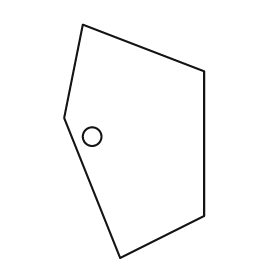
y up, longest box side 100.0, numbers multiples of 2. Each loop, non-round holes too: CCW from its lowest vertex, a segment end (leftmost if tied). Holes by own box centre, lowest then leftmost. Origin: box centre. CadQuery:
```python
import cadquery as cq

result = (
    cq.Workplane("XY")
    .moveTo(-6.0, -50.0)
    .lineTo(30.0, -32.0)
    .lineTo(30.0, 30.0)
    .lineTo(-22.0, 50.0)
    .lineTo(-30.0, 10.0)
    .close()
    .moveTo(-18.0, 2.0)
    .circle(4.0)
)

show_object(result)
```